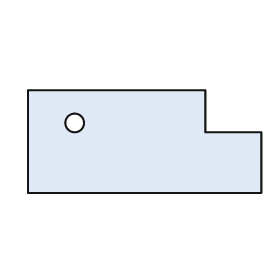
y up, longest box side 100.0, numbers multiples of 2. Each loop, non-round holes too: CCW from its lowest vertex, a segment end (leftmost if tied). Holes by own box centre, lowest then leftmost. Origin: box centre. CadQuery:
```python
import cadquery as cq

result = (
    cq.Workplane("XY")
    .moveTo(-50.0, -22.0)
    .lineTo(50.0, -22.0)
    .lineTo(50.0, 4.0)
    .lineTo(26.0, 4.0)
    .lineTo(26.0, 22.0)
    .lineTo(-50.0, 22.0)
    .close()
    .moveTo(-30.0, 8.0)
    .circle(4.0)
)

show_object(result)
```